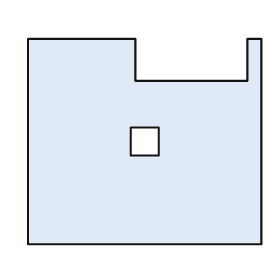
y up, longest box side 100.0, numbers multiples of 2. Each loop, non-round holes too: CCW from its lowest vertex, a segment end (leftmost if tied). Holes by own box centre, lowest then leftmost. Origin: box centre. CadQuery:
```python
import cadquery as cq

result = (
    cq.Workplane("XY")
    .moveTo(-50.0, -44.0)
    .lineTo(50.0, -44.0)
    .lineTo(50.0, 44.0)
    .lineTo(44.0, 44.0)
    .lineTo(44.0, 26.0)
    .lineTo(-4.0, 26.0)
    .lineTo(-4.0, 44.0)
    .lineTo(-50.0, 44.0)
    .close()
    .moveTo(-6.0, -6.0)
    .lineTo(6.0, -6.0)
    .lineTo(6.0, 6.0)
    .lineTo(-6.0, 6.0)
    .close()
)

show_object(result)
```